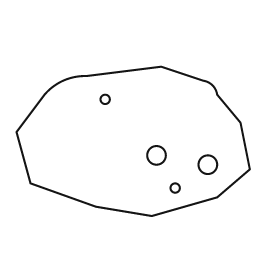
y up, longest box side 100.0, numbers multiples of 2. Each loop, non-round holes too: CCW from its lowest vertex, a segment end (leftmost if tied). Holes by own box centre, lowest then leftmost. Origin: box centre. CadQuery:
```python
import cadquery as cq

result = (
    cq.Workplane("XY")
    .moveTo(8.0, -32.0)
    .lineTo(36.0, -24.0)
    .lineTo(50.0, -12.0)
    .lineTo(46.0, 8.0)
    .lineTo(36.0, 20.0)
    .threePointArc((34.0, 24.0), (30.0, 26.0))
    .lineTo(12.0, 32.0)
    .lineTo(-20.0, 28.0)
    .threePointArc((-30.0, 26.0), (-38.0, 20.0))
    .lineTo(-50.0, 4.0)
    .lineTo(-44.0, -18.0)
    .lineTo(-16.0, -28.0)
    .close()
    .moveTo(18.0, -20.0)
    .circle(2.0)
    .moveTo(32.0, -10.0)
    .circle(4.0)
    .moveTo(10.0, -6.0)
    .circle(4.0)
    .moveTo(-12.0, 18.0)
    .circle(2.0)
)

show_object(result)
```